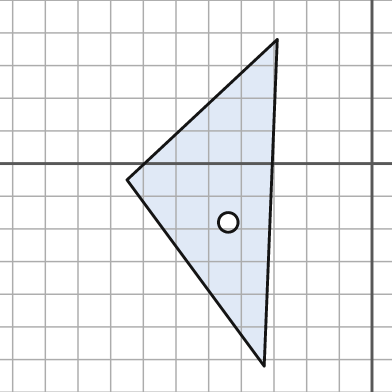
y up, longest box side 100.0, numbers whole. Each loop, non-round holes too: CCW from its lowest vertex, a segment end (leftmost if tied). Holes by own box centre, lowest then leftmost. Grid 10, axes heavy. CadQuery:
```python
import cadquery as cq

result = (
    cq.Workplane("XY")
    .moveTo(-33.0, -62.0)
    .lineTo(-29.0, 38.0)
    .lineTo(-75.0, -5.0)
    .close()
    .moveTo(-44.0, -18.0)
    .circle(3.0)
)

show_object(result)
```